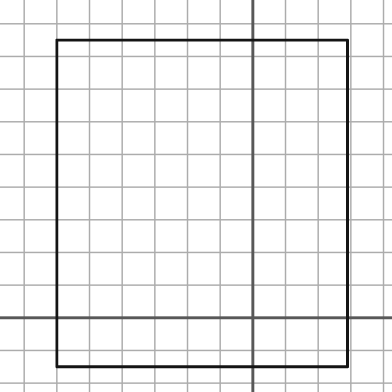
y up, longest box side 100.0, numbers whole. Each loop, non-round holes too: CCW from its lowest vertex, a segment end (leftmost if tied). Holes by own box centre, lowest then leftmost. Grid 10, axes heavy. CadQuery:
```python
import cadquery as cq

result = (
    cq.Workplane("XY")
    .moveTo(-60.0, -15.0)
    .lineTo(29.0, -15.0)
    .lineTo(29.0, 85.0)
    .lineTo(-60.0, 85.0)
    .close()
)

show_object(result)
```